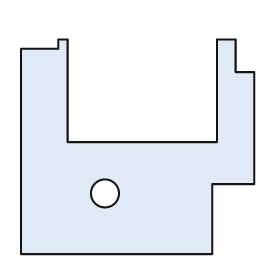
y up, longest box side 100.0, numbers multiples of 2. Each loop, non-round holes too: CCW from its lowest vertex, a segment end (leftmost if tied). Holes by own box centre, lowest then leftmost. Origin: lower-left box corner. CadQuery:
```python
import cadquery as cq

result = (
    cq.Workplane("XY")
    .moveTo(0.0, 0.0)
    .lineTo(82.0, 0.0)
    .lineTo(82.0, 30.0)
    .lineTo(100.0, 30.0)
    .lineTo(100.0, 78.0)
    .lineTo(92.0, 78.0)
    .lineTo(92.0, 92.0)
    .lineTo(84.0, 92.0)
    .lineTo(84.0, 48.0)
    .lineTo(20.0, 48.0)
    .lineTo(20.0, 92.0)
    .lineTo(16.0, 92.0)
    .lineTo(16.0, 88.0)
    .lineTo(0.0, 88.0)
    .close()
    .moveTo(36.0, 26.0)
    .circle(6.0)
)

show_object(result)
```